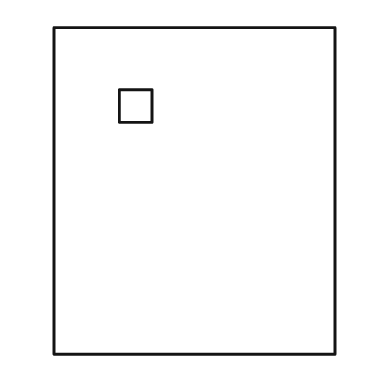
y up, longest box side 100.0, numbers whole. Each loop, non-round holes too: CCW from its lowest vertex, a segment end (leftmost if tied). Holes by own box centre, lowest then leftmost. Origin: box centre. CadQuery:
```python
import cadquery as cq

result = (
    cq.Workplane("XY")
    .moveTo(-43.0, -50.0)
    .lineTo(43.0, -50.0)
    .lineTo(43.0, 50.0)
    .lineTo(-43.0, 50.0)
    .close()
    .moveTo(-23.0, 21.0)
    .lineTo(-13.0, 21.0)
    .lineTo(-13.0, 31.0)
    .lineTo(-23.0, 31.0)
    .close()
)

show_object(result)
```